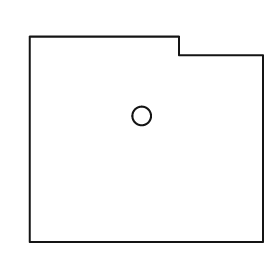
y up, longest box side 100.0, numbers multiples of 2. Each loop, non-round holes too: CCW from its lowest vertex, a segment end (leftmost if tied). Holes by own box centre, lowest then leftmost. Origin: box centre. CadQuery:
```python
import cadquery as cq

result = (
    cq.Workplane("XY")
    .moveTo(-50.0, -44.0)
    .lineTo(50.0, -44.0)
    .lineTo(50.0, 36.0)
    .lineTo(14.0, 36.0)
    .lineTo(14.0, 44.0)
    .lineTo(-50.0, 44.0)
    .close()
    .moveTo(-2.0, 10.0)
    .circle(4.0)
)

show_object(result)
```